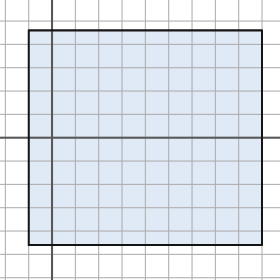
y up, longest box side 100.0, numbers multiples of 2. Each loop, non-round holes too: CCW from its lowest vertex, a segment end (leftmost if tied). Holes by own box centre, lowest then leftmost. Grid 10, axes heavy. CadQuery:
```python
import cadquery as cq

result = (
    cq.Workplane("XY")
    .moveTo(-10.0, -46.0)
    .lineTo(90.0, -46.0)
    .lineTo(90.0, 46.0)
    .lineTo(-10.0, 46.0)
    .close()
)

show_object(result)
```